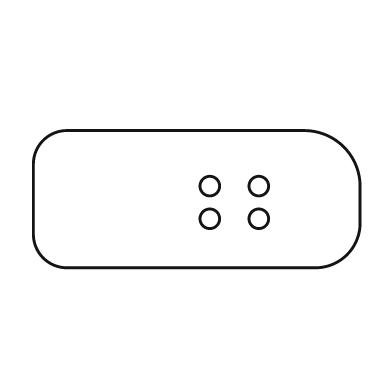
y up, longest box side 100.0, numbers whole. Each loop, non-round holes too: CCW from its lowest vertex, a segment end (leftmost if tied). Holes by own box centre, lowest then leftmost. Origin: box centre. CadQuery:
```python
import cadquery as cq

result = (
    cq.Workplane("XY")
    .moveTo(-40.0, -21.0)
    .lineTo(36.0, -21.0)
    .threePointArc((46.0, -17.0), (50.0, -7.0))
    .lineTo(50.0, 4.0)
    .threePointArc((45.0, 16.0), (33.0, 21.0))
    .lineTo(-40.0, 21.0)
    .threePointArc((-47.0, 18.0), (-50.0, 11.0))
    .lineTo(-50.0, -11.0)
    .threePointArc((-47.0, -18.0), (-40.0, -21.0))
    .close()
    .moveTo(4.0, -6.0)
    .circle(3.0)
    .moveTo(19.0, -6.0)
    .circle(3.0)
    .moveTo(4.0, 4.0)
    .circle(3.0)
    .moveTo(19.0, 4.0)
    .circle(3.0)
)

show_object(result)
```